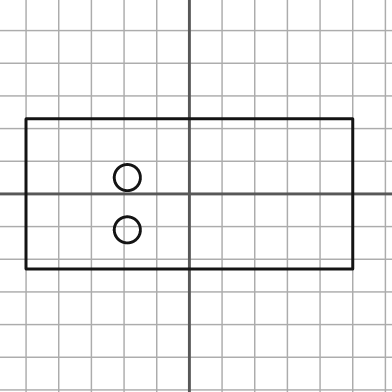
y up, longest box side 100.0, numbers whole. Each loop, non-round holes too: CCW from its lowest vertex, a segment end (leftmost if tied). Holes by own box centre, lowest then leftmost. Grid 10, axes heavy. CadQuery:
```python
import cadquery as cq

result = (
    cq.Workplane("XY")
    .moveTo(-50.0, -23.0)
    .lineTo(50.0, -23.0)
    .lineTo(50.0, 23.0)
    .lineTo(-50.0, 23.0)
    .close()
    .moveTo(-19.0, -11.0)
    .circle(4.0)
    .moveTo(-19.0, 5.0)
    .circle(4.0)
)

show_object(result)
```